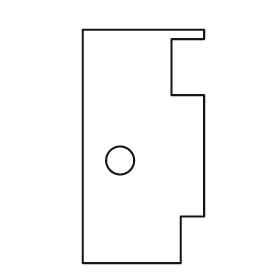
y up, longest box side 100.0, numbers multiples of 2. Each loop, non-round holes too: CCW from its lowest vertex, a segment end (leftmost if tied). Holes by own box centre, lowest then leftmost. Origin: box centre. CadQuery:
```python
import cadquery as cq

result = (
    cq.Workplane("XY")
    .moveTo(-26.0, -50.0)
    .lineTo(16.0, -50.0)
    .lineTo(16.0, -30.0)
    .lineTo(26.0, -30.0)
    .lineTo(26.0, 22.0)
    .lineTo(12.0, 22.0)
    .lineTo(12.0, 46.0)
    .lineTo(26.0, 46.0)
    .lineTo(26.0, 50.0)
    .lineTo(-26.0, 50.0)
    .close()
    .moveTo(-10.0, -6.0)
    .circle(6.0)
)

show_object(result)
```